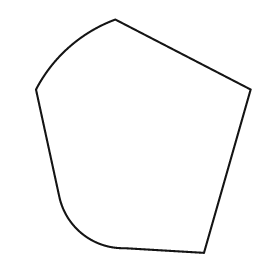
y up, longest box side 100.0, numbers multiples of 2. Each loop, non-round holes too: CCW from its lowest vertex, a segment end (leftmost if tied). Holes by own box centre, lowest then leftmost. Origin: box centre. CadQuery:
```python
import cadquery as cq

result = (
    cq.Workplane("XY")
    .moveTo(26.0, -50.0)
    .lineTo(46.0, 20.0)
    .lineTo(-12.0, 50.0)
    .threePointArc((-32.0, 38.0), (-46.0, 20.0))
    .lineTo(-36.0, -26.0)
    .threePointArc((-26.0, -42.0), (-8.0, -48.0))
    .close()
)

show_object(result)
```